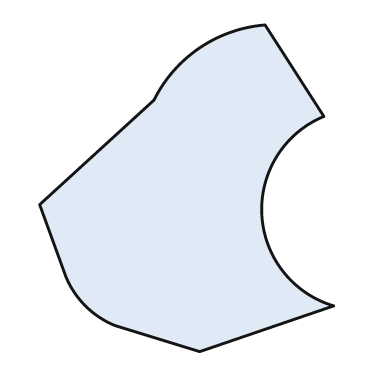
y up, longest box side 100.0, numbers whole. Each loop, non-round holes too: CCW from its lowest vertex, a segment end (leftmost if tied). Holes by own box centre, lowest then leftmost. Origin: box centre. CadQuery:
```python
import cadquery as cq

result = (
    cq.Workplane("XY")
    .moveTo(4.0, -50.0)
    .lineTo(45.0, -36.0)
    .threePointArc((23.0, -8.0), (42.0, 22.0))
    .lineTo(24.0, 50.0)
    .threePointArc((4.0, 43.0), (-10.0, 27.0))
    .lineTo(-45.0, -5.0)
    .lineTo(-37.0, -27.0)
    .threePointArc((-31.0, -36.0), (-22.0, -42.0))
    .close()
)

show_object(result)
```